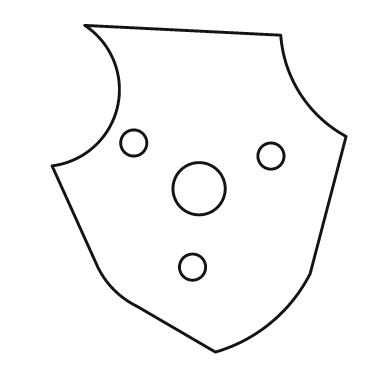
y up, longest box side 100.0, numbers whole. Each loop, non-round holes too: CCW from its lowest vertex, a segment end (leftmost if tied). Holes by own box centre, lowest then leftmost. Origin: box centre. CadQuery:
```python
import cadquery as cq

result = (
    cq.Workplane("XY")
    .moveTo(5.0, -50.0)
    .threePointArc((22.0, -41.0), (34.0, -26.0))
    .lineTo(45.0, 16.0)
    .threePointArc((31.0, 29.0), (25.0, 47.0))
    .lineTo(-35.0, 50.0)
    .threePointArc((-25.0, 25.0), (-45.0, 7.0))
    .lineTo(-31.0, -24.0)
    .threePointArc((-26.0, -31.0), (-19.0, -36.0))
    .close()
    .moveTo(-2.0, -24.0)
    .circle(4.0)
    .moveTo(0.0, 0.0)
    .circle(8.0)
    .moveTo(22.0, 10.0)
    .circle(4.0)
    .moveTo(-20.0, 14.0)
    .circle(4.0)
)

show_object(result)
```